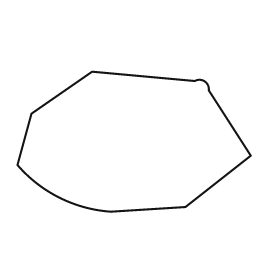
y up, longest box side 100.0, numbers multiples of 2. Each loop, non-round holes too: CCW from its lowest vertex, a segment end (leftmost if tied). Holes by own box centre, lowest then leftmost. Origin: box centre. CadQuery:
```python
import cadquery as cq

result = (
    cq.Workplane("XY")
    .moveTo(-10.0, -30.0)
    .lineTo(22.0, -28.0)
    .lineTo(50.0, -6.0)
    .lineTo(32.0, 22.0)
    .threePointArc((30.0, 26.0), (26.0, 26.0))
    .lineTo(-18.0, 30.0)
    .lineTo(-44.0, 12.0)
    .lineTo(-50.0, -10.0)
    .threePointArc((-32.0, -24.0), (-10.0, -30.0))
    .close()
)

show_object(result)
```